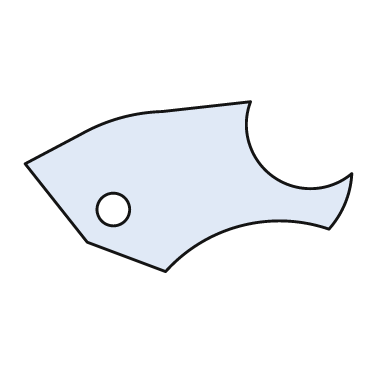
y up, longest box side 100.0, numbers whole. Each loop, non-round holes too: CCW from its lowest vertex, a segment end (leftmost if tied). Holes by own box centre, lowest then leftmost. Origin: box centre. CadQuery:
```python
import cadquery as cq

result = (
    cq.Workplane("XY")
    .moveTo(-7.0, -26.0)
    .threePointArc((16.0, -12.0), (43.0, -13.0))
    .threePointArc((48.0, -5.0), (50.0, 4.0))
    .threePointArc((26.0, 3.0), (19.0, 26.0))
    .lineTo(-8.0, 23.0)
    .threePointArc((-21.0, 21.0), (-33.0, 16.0))
    .lineTo(-50.0, 7.0)
    .lineTo(-31.0, -17.0)
    .close()
    .moveTo(-23.0, -7.0)
    .circle(5.0)
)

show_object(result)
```